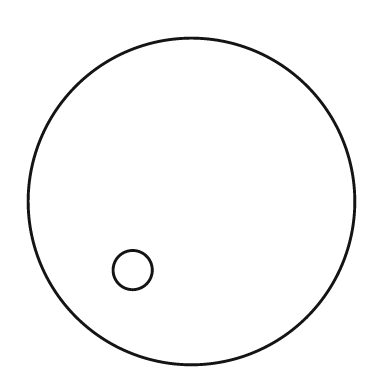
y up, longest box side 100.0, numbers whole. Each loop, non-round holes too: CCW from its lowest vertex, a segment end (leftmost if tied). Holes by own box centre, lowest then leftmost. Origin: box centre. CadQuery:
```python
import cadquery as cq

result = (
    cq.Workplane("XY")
    .moveTo(0.0, 0.0)
    .circle(50.0)
    .moveTo(-18.0, -21.0)
    .circle(6.0)
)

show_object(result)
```